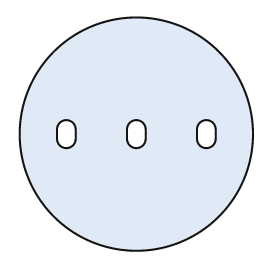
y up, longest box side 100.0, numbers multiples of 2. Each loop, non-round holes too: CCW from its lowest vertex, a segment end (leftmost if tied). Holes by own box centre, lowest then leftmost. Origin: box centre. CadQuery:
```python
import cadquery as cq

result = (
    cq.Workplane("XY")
    .moveTo(0.0, 0.0)
    .circle(50.0)
    .moveTo(-34.0, -2.0)
    .threePointArc((-30.0, -6.0), (-26.0, -2.0))
    .lineTo(-26.0, 2.0)
    .threePointArc((-30.0, 6.0), (-34.0, 2.0))
    .close()
    .moveTo(-4.0, -2.0)
    .threePointArc((0.0, -6.0), (4.0, -2.0))
    .lineTo(4.0, 2.0)
    .threePointArc((0.0, 6.0), (-4.0, 2.0))
    .close()
    .moveTo(26.0, -2.0)
    .threePointArc((30.0, -6.0), (34.0, -2.0))
    .lineTo(34.0, 2.0)
    .threePointArc((30.0, 6.0), (26.0, 2.0))
    .close()
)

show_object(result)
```